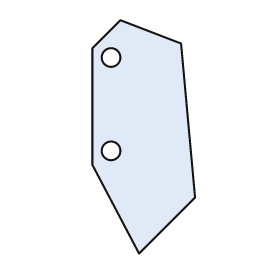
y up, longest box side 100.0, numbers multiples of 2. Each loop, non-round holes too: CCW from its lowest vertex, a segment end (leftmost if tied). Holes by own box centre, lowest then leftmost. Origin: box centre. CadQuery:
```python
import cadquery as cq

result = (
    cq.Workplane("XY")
    .moveTo(-2.0, -50.0)
    .lineTo(22.0, -26.0)
    .lineTo(16.0, 40.0)
    .lineTo(-10.0, 50.0)
    .lineTo(-22.0, 38.0)
    .lineTo(-22.0, -12.0)
    .close()
    .moveTo(-14.0, -6.0)
    .circle(4.0)
    .moveTo(-14.0, 34.0)
    .circle(4.0)
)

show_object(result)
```